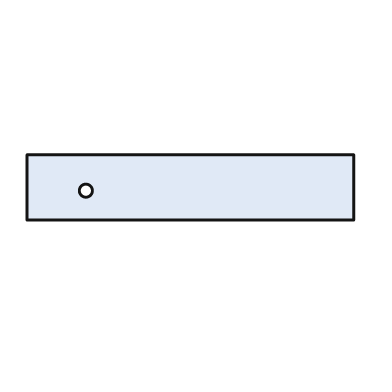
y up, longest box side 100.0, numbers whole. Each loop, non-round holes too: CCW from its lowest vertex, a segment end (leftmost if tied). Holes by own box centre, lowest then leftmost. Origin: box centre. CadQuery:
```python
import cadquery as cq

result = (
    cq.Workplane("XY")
    .moveTo(-50.0, -10.0)
    .lineTo(50.0, -10.0)
    .lineTo(50.0, 10.0)
    .lineTo(-50.0, 10.0)
    .close()
    .moveTo(-32.0, -1.0)
    .circle(2.0)
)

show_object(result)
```